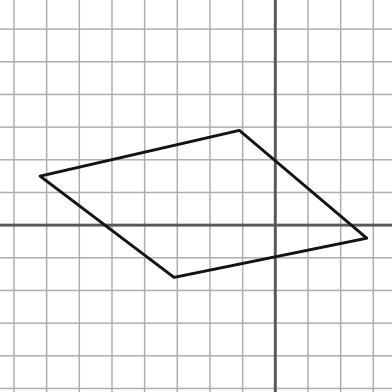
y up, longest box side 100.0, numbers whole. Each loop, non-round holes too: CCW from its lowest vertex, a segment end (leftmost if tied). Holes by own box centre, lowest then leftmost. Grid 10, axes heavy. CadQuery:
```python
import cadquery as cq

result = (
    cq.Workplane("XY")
    .moveTo(-31.0, -16.0)
    .lineTo(28.0, -4.0)
    .lineTo(-11.0, 29.0)
    .lineTo(-72.0, 15.0)
    .close()
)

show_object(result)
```